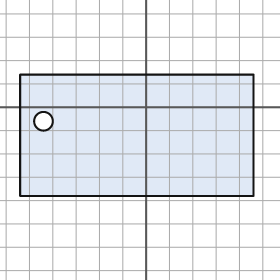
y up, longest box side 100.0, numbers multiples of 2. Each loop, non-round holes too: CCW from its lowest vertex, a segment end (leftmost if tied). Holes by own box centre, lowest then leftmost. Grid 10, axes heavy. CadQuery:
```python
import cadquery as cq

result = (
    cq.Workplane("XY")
    .moveTo(-54.0, -38.0)
    .lineTo(46.0, -38.0)
    .lineTo(46.0, 14.0)
    .lineTo(-54.0, 14.0)
    .close()
    .moveTo(-44.0, -6.0)
    .circle(4.0)
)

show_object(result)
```